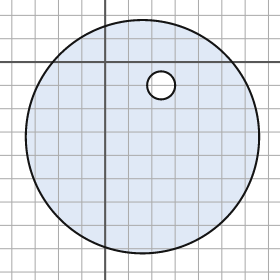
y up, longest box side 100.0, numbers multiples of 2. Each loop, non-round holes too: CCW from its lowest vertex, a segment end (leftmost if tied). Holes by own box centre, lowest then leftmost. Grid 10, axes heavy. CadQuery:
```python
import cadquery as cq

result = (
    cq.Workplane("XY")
    .moveTo(16.0, -32.0)
    .circle(50.0)
    .moveTo(24.0, -10.0)
    .circle(6.0)
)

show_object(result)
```